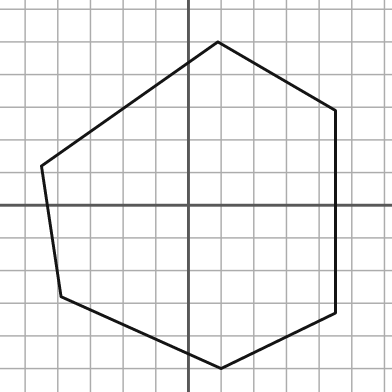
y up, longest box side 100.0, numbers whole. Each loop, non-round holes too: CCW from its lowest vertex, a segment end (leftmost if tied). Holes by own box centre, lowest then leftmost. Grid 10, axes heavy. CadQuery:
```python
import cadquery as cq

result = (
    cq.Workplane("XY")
    .moveTo(10.0, -50.0)
    .lineTo(45.0, -33.0)
    .lineTo(45.0, 29.0)
    .lineTo(9.0, 50.0)
    .lineTo(-45.0, 12.0)
    .lineTo(-39.0, -28.0)
    .close()
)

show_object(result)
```